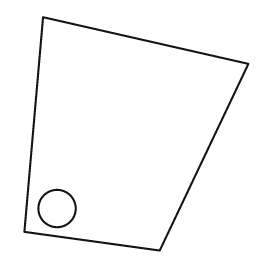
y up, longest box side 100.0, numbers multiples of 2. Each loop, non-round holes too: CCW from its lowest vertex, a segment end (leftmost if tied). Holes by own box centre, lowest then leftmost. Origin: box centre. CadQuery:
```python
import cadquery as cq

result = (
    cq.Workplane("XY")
    .moveTo(10.0, -50.0)
    .lineTo(48.0, 30.0)
    .lineTo(-40.0, 50.0)
    .lineTo(-48.0, -42.0)
    .close()
    .moveTo(-34.0, -32.0)
    .circle(8.0)
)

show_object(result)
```